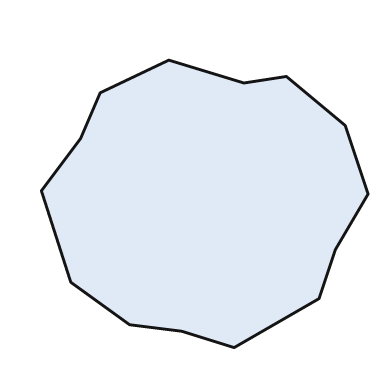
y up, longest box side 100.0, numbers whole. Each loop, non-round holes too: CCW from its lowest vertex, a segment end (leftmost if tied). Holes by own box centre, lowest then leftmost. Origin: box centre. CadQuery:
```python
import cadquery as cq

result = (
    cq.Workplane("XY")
    .moveTo(9.0, -44.0)
    .lineTo(35.0, -29.0)
    .lineTo(40.0, -14.0)
    .lineTo(50.0, 3.0)
    .lineTo(43.0, 24.0)
    .lineTo(25.0, 39.0)
    .lineTo(12.0, 37.0)
    .lineTo(-11.0, 44.0)
    .lineTo(-32.0, 34.0)
    .lineTo(-38.0, 20.0)
    .lineTo(-50.0, 4.0)
    .lineTo(-41.0, -24.0)
    .lineTo(-23.0, -37.0)
    .lineTo(-7.0, -39.0)
    .close()
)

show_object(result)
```